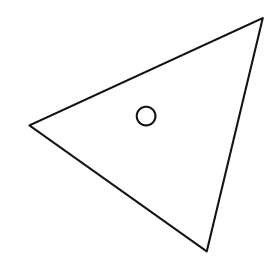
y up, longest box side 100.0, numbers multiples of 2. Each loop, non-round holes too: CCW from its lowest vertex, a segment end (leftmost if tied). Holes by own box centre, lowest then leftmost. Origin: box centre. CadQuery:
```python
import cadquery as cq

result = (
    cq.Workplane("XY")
    .moveTo(26.0, -50.0)
    .lineTo(50.0, 50.0)
    .lineTo(-50.0, 4.0)
    .close()
    .moveTo(0.0, 8.0)
    .circle(4.0)
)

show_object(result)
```